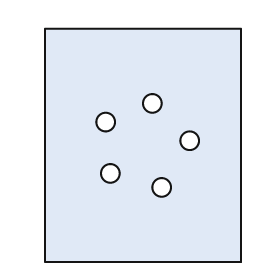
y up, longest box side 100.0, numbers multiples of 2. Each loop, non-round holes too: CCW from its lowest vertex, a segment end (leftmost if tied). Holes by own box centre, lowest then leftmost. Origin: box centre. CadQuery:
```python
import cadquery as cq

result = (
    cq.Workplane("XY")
    .moveTo(-42.0, -50.0)
    .lineTo(42.0, -50.0)
    .lineTo(42.0, 50.0)
    .lineTo(-42.0, 50.0)
    .close()
    .moveTo(8.0, -18.0)
    .circle(4.0)
    .moveTo(-14.0, -12.0)
    .circle(4.0)
    .moveTo(20.0, 2.0)
    .circle(4.0)
    .moveTo(-16.0, 10.0)
    .circle(4.0)
    .moveTo(4.0, 18.0)
    .circle(4.0)
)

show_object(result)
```